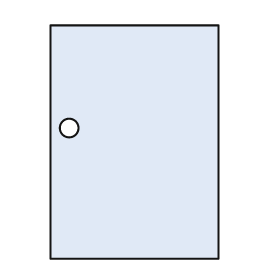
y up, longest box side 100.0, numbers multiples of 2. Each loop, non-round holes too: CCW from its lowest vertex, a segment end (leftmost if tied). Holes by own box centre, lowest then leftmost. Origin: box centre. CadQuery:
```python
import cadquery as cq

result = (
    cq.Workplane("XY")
    .moveTo(-36.0, -50.0)
    .lineTo(36.0, -50.0)
    .lineTo(36.0, 50.0)
    .lineTo(-36.0, 50.0)
    .close()
    .moveTo(-28.0, 6.0)
    .circle(4.0)
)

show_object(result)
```